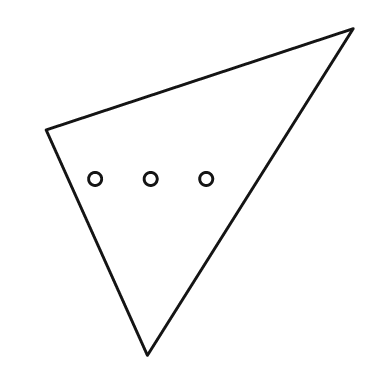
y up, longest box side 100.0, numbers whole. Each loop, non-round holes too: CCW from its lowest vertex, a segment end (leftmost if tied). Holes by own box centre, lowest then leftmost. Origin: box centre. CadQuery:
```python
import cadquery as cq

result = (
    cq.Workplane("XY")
    .moveTo(-16.0, -50.0)
    .lineTo(47.0, 50.0)
    .lineTo(-47.0, 19.0)
    .close()
    .moveTo(-32.0, 4.0)
    .circle(2.0)
    .moveTo(-15.0, 4.0)
    .circle(2.0)
    .moveTo(2.0, 4.0)
    .circle(2.0)
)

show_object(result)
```